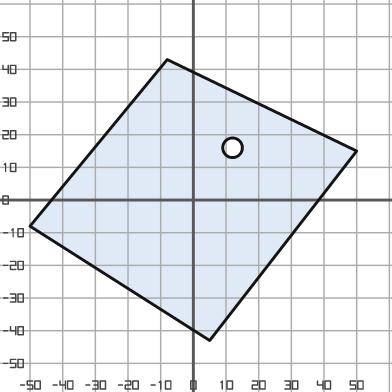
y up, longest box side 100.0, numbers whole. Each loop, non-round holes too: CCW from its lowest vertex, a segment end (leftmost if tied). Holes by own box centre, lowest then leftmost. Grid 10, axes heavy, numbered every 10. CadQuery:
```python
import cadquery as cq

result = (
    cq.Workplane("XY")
    .moveTo(5.0, -43.0)
    .lineTo(50.0, 15.0)
    .lineTo(-8.0, 43.0)
    .lineTo(-50.0, -8.0)
    .close()
    .moveTo(12.0, 16.0)
    .circle(3.0)
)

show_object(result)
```